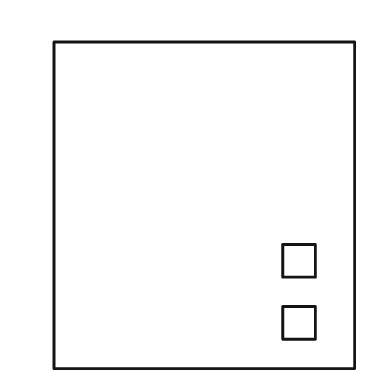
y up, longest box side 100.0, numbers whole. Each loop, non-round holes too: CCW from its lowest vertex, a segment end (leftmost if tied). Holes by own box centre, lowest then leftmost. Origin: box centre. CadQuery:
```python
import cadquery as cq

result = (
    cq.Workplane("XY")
    .moveTo(-46.0, -50.0)
    .lineTo(46.0, -50.0)
    .lineTo(46.0, 50.0)
    .lineTo(-46.0, 50.0)
    .close()
    .moveTo(24.0, -41.0)
    .lineTo(34.0, -41.0)
    .lineTo(34.0, -31.0)
    .lineTo(24.0, -31.0)
    .close()
    .moveTo(24.0, -22.0)
    .lineTo(34.0, -22.0)
    .lineTo(34.0, -12.0)
    .lineTo(24.0, -12.0)
    .close()
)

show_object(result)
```